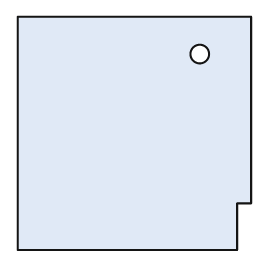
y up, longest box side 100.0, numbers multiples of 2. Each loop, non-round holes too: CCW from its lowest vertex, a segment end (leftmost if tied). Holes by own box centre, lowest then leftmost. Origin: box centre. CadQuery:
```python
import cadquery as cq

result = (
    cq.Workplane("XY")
    .moveTo(-50.0, -50.0)
    .lineTo(44.0, -50.0)
    .lineTo(44.0, -30.0)
    .lineTo(50.0, -30.0)
    .lineTo(50.0, 50.0)
    .lineTo(-50.0, 50.0)
    .close()
    .moveTo(28.0, 34.0)
    .circle(4.0)
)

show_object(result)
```